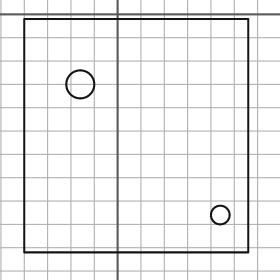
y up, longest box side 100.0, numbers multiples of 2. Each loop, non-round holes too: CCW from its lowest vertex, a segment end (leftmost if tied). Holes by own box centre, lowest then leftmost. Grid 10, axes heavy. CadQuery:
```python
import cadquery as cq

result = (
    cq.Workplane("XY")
    .moveTo(-40.0, -102.0)
    .lineTo(56.0, -102.0)
    .lineTo(56.0, -2.0)
    .lineTo(-40.0, -2.0)
    .close()
    .moveTo(44.0, -86.0)
    .circle(4.0)
    .moveTo(-16.0, -30.0)
    .circle(6.0)
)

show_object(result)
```